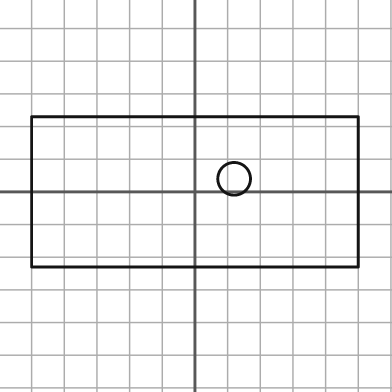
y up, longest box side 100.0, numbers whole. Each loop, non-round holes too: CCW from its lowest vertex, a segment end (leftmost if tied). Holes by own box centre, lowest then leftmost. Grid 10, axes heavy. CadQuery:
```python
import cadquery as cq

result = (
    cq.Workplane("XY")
    .moveTo(-50.0, -23.0)
    .lineTo(50.0, -23.0)
    .lineTo(50.0, 23.0)
    .lineTo(-50.0, 23.0)
    .close()
    .moveTo(12.0, 4.0)
    .circle(5.0)
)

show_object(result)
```